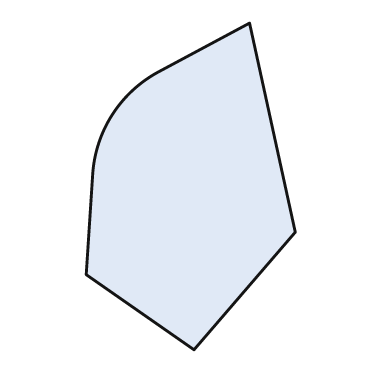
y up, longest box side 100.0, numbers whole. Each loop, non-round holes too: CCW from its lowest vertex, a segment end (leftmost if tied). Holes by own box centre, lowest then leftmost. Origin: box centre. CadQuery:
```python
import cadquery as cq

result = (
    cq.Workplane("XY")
    .moveTo(1.0, -50.0)
    .lineTo(32.0, -14.0)
    .lineTo(18.0, 50.0)
    .lineTo(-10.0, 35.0)
    .threePointArc((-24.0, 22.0), (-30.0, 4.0))
    .lineTo(-32.0, -27.0)
    .close()
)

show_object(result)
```